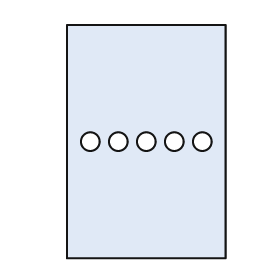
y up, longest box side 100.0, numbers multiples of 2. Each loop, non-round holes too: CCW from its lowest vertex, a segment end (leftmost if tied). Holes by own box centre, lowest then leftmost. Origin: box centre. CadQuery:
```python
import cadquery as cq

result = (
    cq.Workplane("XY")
    .moveTo(-34.0, -50.0)
    .lineTo(34.0, -50.0)
    .lineTo(34.0, 50.0)
    .lineTo(-34.0, 50.0)
    .close()
    .moveTo(-24.0, 0.0)
    .circle(4.0)
    .moveTo(-12.0, 0.0)
    .circle(4.0)
    .moveTo(0.0, 0.0)
    .circle(4.0)
    .moveTo(12.0, 0.0)
    .circle(4.0)
    .moveTo(24.0, 0.0)
    .circle(4.0)
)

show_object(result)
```